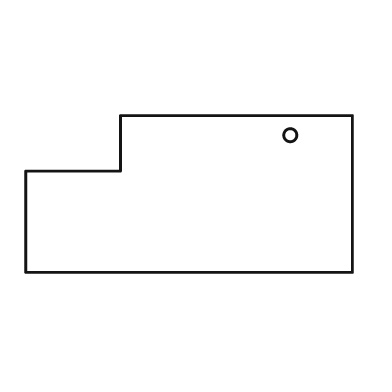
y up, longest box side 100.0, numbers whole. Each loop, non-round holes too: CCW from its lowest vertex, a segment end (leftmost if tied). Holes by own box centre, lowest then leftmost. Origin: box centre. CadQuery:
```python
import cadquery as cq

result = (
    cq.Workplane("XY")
    .moveTo(-50.0, -24.0)
    .lineTo(50.0, -24.0)
    .lineTo(50.0, 24.0)
    .lineTo(-21.0, 24.0)
    .lineTo(-21.0, 7.0)
    .lineTo(-50.0, 7.0)
    .close()
    .moveTo(31.0, 18.0)
    .circle(2.0)
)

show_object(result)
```